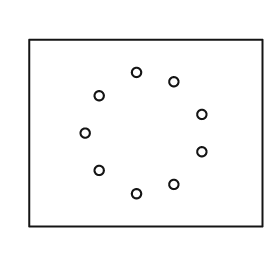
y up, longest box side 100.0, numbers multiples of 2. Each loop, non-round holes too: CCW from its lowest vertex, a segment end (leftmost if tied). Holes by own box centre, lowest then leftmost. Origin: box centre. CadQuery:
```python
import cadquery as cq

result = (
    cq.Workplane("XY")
    .moveTo(-50.0, -40.0)
    .lineTo(50.0, -40.0)
    .lineTo(50.0, 40.0)
    .lineTo(-50.0, 40.0)
    .close()
    .moveTo(-4.0, -26.0)
    .circle(2.0)
    .moveTo(12.0, -22.0)
    .circle(2.0)
    .moveTo(-20.0, -16.0)
    .circle(2.0)
    .moveTo(24.0, -8.0)
    .circle(2.0)
    .moveTo(-26.0, 0.0)
    .circle(2.0)
    .moveTo(24.0, 8.0)
    .circle(2.0)
    .moveTo(-20.0, 16.0)
    .circle(2.0)
    .moveTo(12.0, 22.0)
    .circle(2.0)
    .moveTo(-4.0, 26.0)
    .circle(2.0)
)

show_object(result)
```